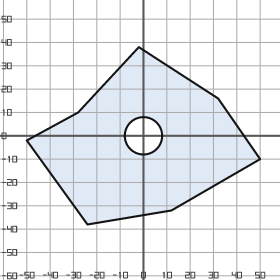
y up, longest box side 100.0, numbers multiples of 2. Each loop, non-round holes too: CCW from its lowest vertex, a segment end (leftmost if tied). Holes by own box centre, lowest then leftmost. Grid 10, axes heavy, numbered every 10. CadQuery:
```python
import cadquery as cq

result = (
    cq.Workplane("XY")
    .moveTo(-24.0, -38.0)
    .lineTo(12.0, -32.0)
    .lineTo(50.0, -10.0)
    .lineTo(32.0, 16.0)
    .lineTo(-2.0, 38.0)
    .lineTo(-28.0, 10.0)
    .lineTo(-50.0, -2.0)
    .close()
    .moveTo(0.0, 0.0)
    .circle(8.0)
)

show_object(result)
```